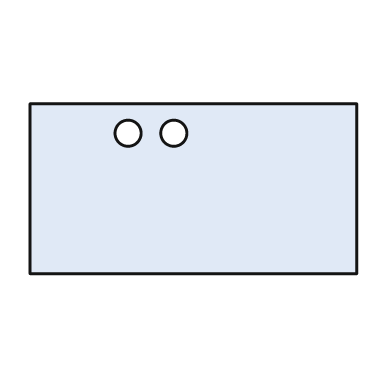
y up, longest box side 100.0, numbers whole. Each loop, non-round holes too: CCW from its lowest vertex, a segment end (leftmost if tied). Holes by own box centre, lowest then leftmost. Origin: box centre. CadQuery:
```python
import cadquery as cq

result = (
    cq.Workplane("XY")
    .moveTo(-50.0, -26.0)
    .lineTo(50.0, -26.0)
    .lineTo(50.0, 26.0)
    .lineTo(-50.0, 26.0)
    .close()
    .moveTo(-20.0, 17.0)
    .circle(4.0)
    .moveTo(-6.0, 17.0)
    .circle(4.0)
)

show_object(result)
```